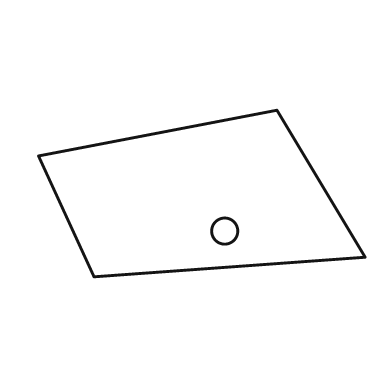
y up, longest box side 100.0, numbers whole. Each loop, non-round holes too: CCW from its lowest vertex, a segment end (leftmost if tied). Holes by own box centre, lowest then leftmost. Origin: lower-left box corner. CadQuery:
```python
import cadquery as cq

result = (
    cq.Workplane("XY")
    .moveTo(17.0, 0.0)
    .lineTo(100.0, 6.0)
    .lineTo(73.0, 51.0)
    .lineTo(0.0, 37.0)
    .close()
    .moveTo(57.0, 14.0)
    .circle(4.0)
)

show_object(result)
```